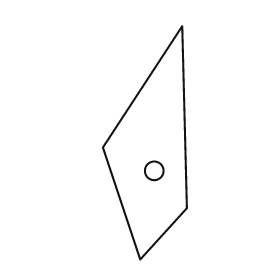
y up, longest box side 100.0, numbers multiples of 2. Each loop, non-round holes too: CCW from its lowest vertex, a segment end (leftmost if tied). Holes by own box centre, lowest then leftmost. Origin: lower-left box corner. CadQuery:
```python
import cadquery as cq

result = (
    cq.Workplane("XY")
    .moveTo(16.0, 0.0)
    .lineTo(36.0, 22.0)
    .lineTo(34.0, 100.0)
    .lineTo(0.0, 48.0)
    .close()
    .moveTo(22.0, 38.0)
    .circle(4.0)
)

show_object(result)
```